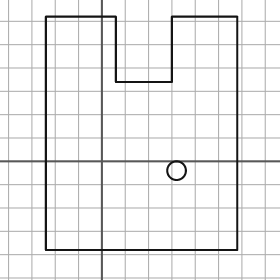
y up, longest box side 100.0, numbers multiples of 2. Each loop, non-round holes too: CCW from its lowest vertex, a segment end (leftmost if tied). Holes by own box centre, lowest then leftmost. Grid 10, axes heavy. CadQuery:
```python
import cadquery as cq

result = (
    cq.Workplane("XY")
    .moveTo(-24.0, -38.0)
    .lineTo(58.0, -38.0)
    .lineTo(58.0, 62.0)
    .lineTo(30.0, 62.0)
    .lineTo(30.0, 34.0)
    .lineTo(6.0, 34.0)
    .lineTo(6.0, 62.0)
    .lineTo(-24.0, 62.0)
    .close()
    .moveTo(32.0, -4.0)
    .circle(4.0)
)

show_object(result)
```